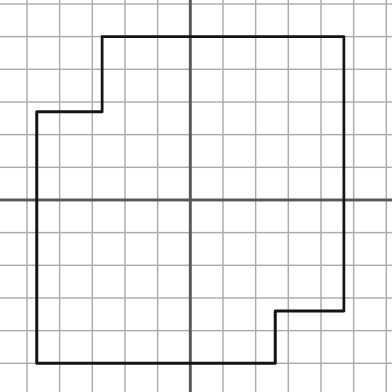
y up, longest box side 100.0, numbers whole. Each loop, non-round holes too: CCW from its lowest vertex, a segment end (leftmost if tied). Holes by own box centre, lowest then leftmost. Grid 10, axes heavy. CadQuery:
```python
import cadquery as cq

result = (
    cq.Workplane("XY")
    .moveTo(-47.0, -50.0)
    .lineTo(26.0, -50.0)
    .lineTo(26.0, -34.0)
    .lineTo(47.0, -34.0)
    .lineTo(47.0, 50.0)
    .lineTo(-27.0, 50.0)
    .lineTo(-27.0, 27.0)
    .lineTo(-47.0, 27.0)
    .close()
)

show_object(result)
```